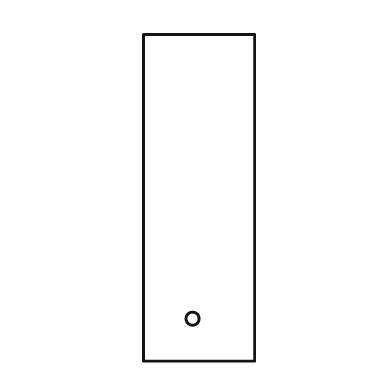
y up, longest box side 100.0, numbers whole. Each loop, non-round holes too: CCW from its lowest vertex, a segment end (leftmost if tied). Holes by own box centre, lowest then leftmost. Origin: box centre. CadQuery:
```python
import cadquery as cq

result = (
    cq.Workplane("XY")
    .moveTo(-17.0, -50.0)
    .lineTo(17.0, -50.0)
    .lineTo(17.0, 50.0)
    .lineTo(-17.0, 50.0)
    .close()
    .moveTo(-2.0, -37.0)
    .circle(2.0)
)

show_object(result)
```